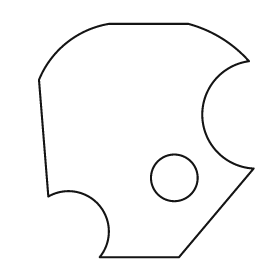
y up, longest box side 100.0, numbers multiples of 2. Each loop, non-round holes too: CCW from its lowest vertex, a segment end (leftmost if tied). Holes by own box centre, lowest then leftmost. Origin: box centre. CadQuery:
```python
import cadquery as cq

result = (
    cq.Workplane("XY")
    .moveTo(-20.0, -50.0)
    .lineTo(14.0, -50.0)
    .lineTo(46.0, -12.0)
    .threePointArc((24.0, 10.0), (44.0, 34.0))
    .threePointArc((32.0, 44.0), (18.0, 50.0))
    .lineTo(-16.0, 50.0)
    .threePointArc((-34.0, 42.0), (-46.0, 26.0))
    .lineTo(-42.0, -24.0)
    .threePointArc((-20.0, -28.0), (-20.0, -50.0))
    .close()
    .moveTo(12.0, -16.0)
    .circle(10.0)
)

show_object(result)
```